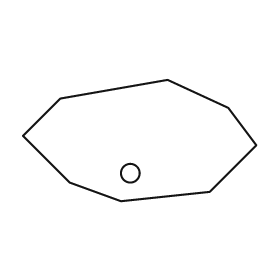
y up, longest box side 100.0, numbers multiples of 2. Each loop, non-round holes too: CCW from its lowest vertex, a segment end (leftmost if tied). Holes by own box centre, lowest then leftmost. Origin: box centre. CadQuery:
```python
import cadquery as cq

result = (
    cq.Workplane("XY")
    .moveTo(-8.0, -26.0)
    .lineTo(30.0, -22.0)
    .lineTo(50.0, -2.0)
    .lineTo(38.0, 14.0)
    .lineTo(12.0, 26.0)
    .lineTo(-34.0, 18.0)
    .lineTo(-50.0, 2.0)
    .lineTo(-30.0, -18.0)
    .close()
    .moveTo(-4.0, -14.0)
    .circle(4.0)
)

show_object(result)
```